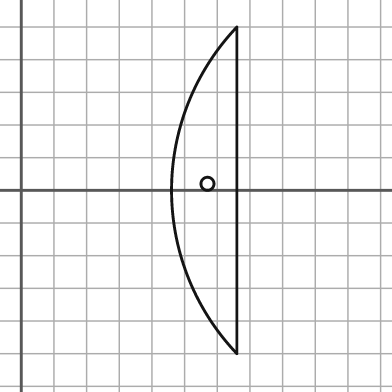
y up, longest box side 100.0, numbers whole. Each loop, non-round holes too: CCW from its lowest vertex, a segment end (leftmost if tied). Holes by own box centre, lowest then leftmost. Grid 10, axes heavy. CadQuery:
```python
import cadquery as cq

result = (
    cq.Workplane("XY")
    .moveTo(66.0, -50.0)
    .lineTo(66.0, 50.0)
    .threePointArc((46.0, 0.0), (66.0, -50.0))
    .close()
    .moveTo(57.0, 2.0)
    .circle(2.0)
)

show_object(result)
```